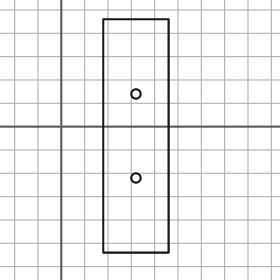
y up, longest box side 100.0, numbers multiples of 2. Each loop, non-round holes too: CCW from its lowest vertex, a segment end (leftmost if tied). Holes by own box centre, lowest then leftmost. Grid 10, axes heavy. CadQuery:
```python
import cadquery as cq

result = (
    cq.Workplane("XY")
    .moveTo(18.0, -54.0)
    .lineTo(46.0, -54.0)
    .lineTo(46.0, 46.0)
    .lineTo(18.0, 46.0)
    .close()
    .moveTo(32.0, -22.0)
    .circle(2.0)
    .moveTo(32.0, 14.0)
    .circle(2.0)
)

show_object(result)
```